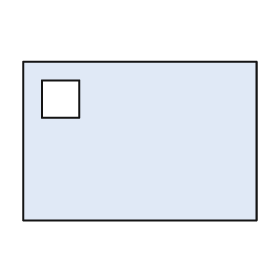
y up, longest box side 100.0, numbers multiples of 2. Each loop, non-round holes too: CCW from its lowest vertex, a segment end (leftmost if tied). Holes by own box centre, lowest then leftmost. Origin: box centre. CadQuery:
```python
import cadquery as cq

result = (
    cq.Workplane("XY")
    .moveTo(-50.0, -34.0)
    .lineTo(50.0, -34.0)
    .lineTo(50.0, 34.0)
    .lineTo(-50.0, 34.0)
    .close()
    .moveTo(-42.0, 10.0)
    .lineTo(-26.0, 10.0)
    .lineTo(-26.0, 26.0)
    .lineTo(-42.0, 26.0)
    .close()
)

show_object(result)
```